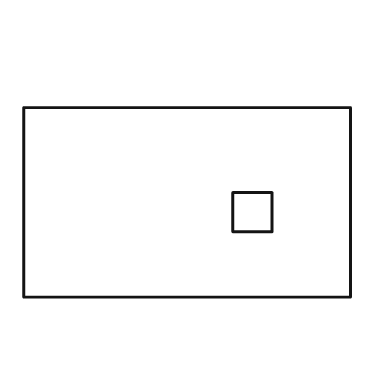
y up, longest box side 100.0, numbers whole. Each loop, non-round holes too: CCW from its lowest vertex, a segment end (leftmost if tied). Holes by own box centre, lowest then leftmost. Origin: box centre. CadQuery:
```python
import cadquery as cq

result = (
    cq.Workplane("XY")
    .moveTo(-50.0, -29.0)
    .lineTo(50.0, -29.0)
    .lineTo(50.0, 29.0)
    .lineTo(-50.0, 29.0)
    .close()
    .moveTo(14.0, -9.0)
    .lineTo(26.0, -9.0)
    .lineTo(26.0, 3.0)
    .lineTo(14.0, 3.0)
    .close()
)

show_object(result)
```